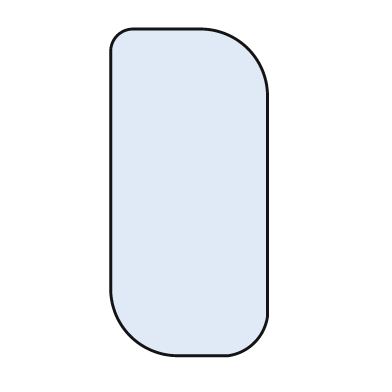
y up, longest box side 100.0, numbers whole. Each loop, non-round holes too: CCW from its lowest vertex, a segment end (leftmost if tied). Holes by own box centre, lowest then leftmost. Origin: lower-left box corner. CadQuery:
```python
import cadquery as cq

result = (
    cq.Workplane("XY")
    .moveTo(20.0, 0.0)
    .lineTo(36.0, 0.0)
    .threePointArc((44.0, 4.0), (48.0, 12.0))
    .lineTo(48.0, 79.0)
    .threePointArc((42.0, 94.0), (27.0, 100.0))
    .lineTo(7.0, 100.0)
    .threePointArc((2.0, 98.0), (0.0, 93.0))
    .lineTo(0.0, 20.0)
    .threePointArc((6.0, 6.0), (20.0, 0.0))
    .close()
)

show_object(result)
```